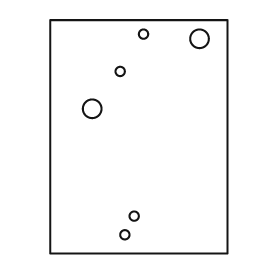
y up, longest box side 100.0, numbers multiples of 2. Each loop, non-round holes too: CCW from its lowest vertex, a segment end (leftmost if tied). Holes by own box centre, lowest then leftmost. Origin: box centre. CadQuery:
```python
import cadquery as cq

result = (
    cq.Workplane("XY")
    .moveTo(-38.0, -50.0)
    .lineTo(38.0, -50.0)
    .lineTo(38.0, 50.0)
    .lineTo(-38.0, 50.0)
    .close()
    .moveTo(-6.0, -42.0)
    .circle(2.0)
    .moveTo(-2.0, -34.0)
    .circle(2.0)
    .moveTo(-20.0, 12.0)
    .circle(4.0)
    .moveTo(-8.0, 28.0)
    .circle(2.0)
    .moveTo(26.0, 42.0)
    .circle(4.0)
    .moveTo(2.0, 44.0)
    .circle(2.0)
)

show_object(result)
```